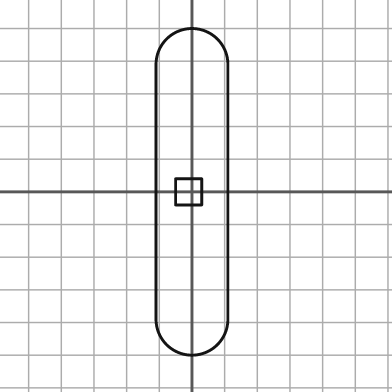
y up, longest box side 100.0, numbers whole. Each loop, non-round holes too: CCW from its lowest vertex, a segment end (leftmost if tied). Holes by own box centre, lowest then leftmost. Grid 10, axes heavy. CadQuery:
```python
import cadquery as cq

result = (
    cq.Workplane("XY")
    .moveTo(-11.0, -39.0)
    .threePointArc((0.0, -50.0), (11.0, -39.0))
    .lineTo(11.0, 39.0)
    .threePointArc((0.0, 50.0), (-11.0, 39.0))
    .close()
    .moveTo(-5.0, -4.0)
    .lineTo(3.0, -4.0)
    .lineTo(3.0, 4.0)
    .lineTo(-5.0, 4.0)
    .close()
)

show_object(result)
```